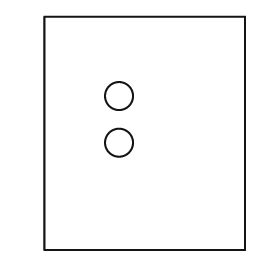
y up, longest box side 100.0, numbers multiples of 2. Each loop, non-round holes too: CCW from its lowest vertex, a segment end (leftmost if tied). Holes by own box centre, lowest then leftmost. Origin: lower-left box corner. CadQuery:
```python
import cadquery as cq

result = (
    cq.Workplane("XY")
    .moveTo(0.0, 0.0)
    .lineTo(86.0, 0.0)
    .lineTo(86.0, 100.0)
    .lineTo(0.0, 100.0)
    .close()
    .moveTo(32.0, 46.0)
    .circle(6.0)
    .moveTo(32.0, 66.0)
    .circle(6.0)
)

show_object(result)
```